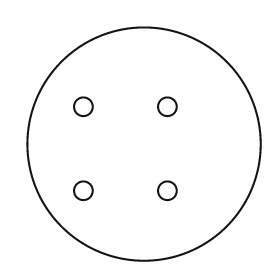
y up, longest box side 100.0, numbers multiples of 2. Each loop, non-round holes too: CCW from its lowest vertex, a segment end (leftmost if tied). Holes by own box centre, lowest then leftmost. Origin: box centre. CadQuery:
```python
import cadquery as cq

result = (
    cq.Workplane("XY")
    .moveTo(0.0, 0.0)
    .circle(50.0)
    .moveTo(-26.0, -20.0)
    .circle(4.0)
    .moveTo(10.0, -20.0)
    .circle(4.0)
    .moveTo(-26.0, 16.0)
    .circle(4.0)
    .moveTo(10.0, 16.0)
    .circle(4.0)
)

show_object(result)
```